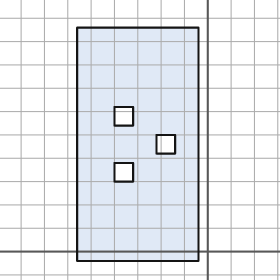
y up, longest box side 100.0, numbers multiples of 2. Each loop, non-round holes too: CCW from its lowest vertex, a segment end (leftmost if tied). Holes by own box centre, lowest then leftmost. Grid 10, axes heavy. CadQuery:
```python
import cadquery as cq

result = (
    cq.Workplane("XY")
    .moveTo(-56.0, -4.0)
    .lineTo(-4.0, -4.0)
    .lineTo(-4.0, 96.0)
    .lineTo(-56.0, 96.0)
    .close()
    .moveTo(-40.0, 30.0)
    .lineTo(-32.0, 30.0)
    .lineTo(-32.0, 38.0)
    .lineTo(-40.0, 38.0)
    .close()
    .moveTo(-22.0, 42.0)
    .lineTo(-14.0, 42.0)
    .lineTo(-14.0, 50.0)
    .lineTo(-22.0, 50.0)
    .close()
    .moveTo(-40.0, 54.0)
    .lineTo(-32.0, 54.0)
    .lineTo(-32.0, 62.0)
    .lineTo(-40.0, 62.0)
    .close()
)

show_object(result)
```